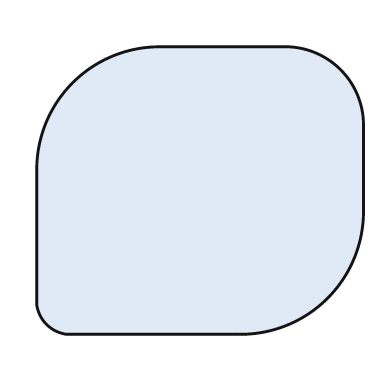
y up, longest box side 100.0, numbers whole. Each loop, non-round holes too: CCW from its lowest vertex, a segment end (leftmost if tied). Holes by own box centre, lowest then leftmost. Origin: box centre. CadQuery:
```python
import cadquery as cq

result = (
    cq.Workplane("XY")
    .moveTo(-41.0, -44.0)
    .lineTo(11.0, -44.0)
    .threePointArc((39.0, -33.0), (50.0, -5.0))
    .lineTo(50.0, 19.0)
    .threePointArc((43.0, 37.0), (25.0, 44.0))
    .lineTo(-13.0, 44.0)
    .threePointArc((-39.0, 33.0), (-50.0, 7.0))
    .lineTo(-50.0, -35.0)
    .threePointArc((-47.0, -41.0), (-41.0, -44.0))
    .close()
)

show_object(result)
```